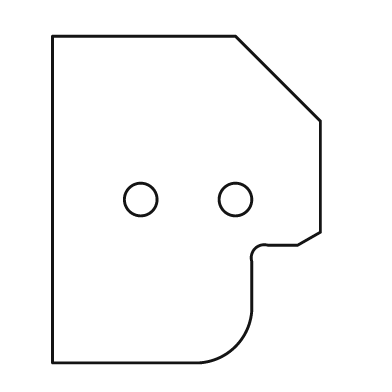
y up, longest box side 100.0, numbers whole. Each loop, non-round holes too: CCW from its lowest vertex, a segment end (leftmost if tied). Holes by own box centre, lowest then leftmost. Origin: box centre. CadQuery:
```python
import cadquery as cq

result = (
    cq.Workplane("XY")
    .moveTo(-41.0, -50.0)
    .lineTo(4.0, -50.0)
    .threePointArc((15.0, -45.0), (20.0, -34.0))
    .lineTo(20.0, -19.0)
    .threePointArc((21.0, -15.0), (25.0, -14.0))
    .lineTo(34.0, -14.0)
    .lineTo(41.0, -10.0)
    .lineTo(41.0, 24.0)
    .lineTo(15.0, 50.0)
    .lineTo(-41.0, 50.0)
    .close()
    .moveTo(-14.0, 0.0)
    .circle(5.0)
    .moveTo(15.0, 0.0)
    .circle(5.0)
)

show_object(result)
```